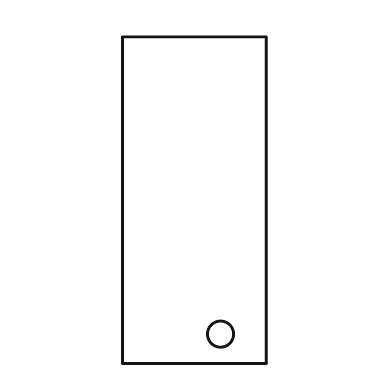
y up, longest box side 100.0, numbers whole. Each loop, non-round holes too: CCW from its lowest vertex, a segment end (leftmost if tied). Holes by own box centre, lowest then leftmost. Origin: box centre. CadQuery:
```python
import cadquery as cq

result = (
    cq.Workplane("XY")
    .moveTo(-22.0, -50.0)
    .lineTo(22.0, -50.0)
    .lineTo(22.0, 50.0)
    .lineTo(-22.0, 50.0)
    .close()
    .moveTo(8.0, -41.0)
    .circle(4.0)
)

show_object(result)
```